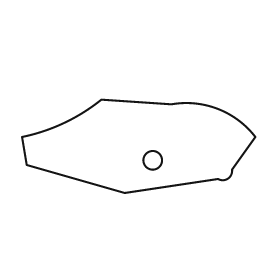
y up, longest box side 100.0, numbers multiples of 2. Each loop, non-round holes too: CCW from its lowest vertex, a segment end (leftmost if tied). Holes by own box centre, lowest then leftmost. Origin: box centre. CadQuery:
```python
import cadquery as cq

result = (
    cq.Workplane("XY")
    .moveTo(-6.0, -20.0)
    .lineTo(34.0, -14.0)
    .threePointArc((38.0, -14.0), (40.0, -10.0))
    .lineTo(50.0, 4.0)
    .threePointArc((34.0, 16.0), (14.0, 18.0))
    .lineTo(-16.0, 20.0)
    .threePointArc((-32.0, 10.0), (-50.0, 4.0))
    .lineTo(-48.0, -8.0)
    .close()
    .moveTo(6.0, -6.0)
    .circle(4.0)
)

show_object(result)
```